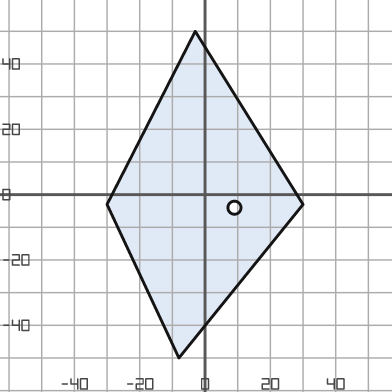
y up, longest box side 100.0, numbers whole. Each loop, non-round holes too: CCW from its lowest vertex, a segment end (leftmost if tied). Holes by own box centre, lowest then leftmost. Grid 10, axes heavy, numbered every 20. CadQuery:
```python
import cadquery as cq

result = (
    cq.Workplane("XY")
    .moveTo(-8.0, -50.0)
    .lineTo(30.0, -3.0)
    .lineTo(-3.0, 50.0)
    .lineTo(-30.0, -3.0)
    .close()
    .moveTo(9.0, -4.0)
    .circle(2.0)
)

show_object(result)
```